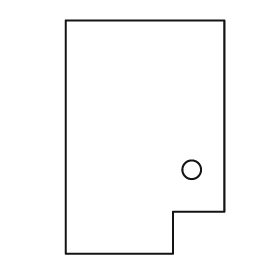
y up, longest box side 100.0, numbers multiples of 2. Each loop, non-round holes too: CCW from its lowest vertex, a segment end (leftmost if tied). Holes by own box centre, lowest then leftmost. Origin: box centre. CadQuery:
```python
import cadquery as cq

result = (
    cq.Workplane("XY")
    .moveTo(-34.0, -50.0)
    .lineTo(12.0, -50.0)
    .lineTo(12.0, -32.0)
    .lineTo(34.0, -32.0)
    .lineTo(34.0, 50.0)
    .lineTo(-34.0, 50.0)
    .close()
    .moveTo(20.0, -14.0)
    .circle(4.0)
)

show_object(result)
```